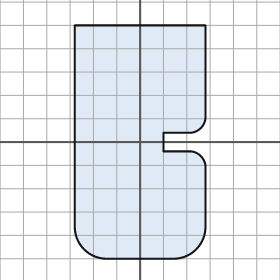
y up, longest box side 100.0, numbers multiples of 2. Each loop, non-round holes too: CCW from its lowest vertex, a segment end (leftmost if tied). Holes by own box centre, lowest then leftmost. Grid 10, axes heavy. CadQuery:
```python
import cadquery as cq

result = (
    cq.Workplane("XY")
    .moveTo(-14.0, -50.0)
    .lineTo(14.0, -50.0)
    .threePointArc((24.0, -46.0), (28.0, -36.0))
    .lineTo(28.0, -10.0)
    .threePointArc((26.0, -6.0), (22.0, -4.0))
    .lineTo(10.0, -4.0)
    .lineTo(10.0, 4.0)
    .lineTo(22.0, 4.0)
    .threePointArc((26.0, 6.0), (28.0, 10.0))
    .lineTo(28.0, 50.0)
    .lineTo(-28.0, 50.0)
    .lineTo(-28.0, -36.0)
    .threePointArc((-24.0, -46.0), (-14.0, -50.0))
    .close()
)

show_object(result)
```